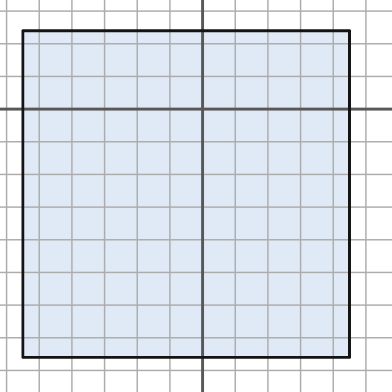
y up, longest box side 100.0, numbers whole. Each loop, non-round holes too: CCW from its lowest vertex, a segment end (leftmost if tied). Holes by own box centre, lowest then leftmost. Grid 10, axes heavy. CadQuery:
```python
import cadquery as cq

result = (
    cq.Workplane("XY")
    .moveTo(-55.0, -76.0)
    .lineTo(45.0, -76.0)
    .lineTo(45.0, 24.0)
    .lineTo(-55.0, 24.0)
    .close()
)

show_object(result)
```